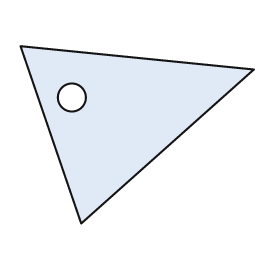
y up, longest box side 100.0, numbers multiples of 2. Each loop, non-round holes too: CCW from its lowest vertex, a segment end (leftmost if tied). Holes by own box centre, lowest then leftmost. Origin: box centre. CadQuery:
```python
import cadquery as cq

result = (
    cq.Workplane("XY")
    .moveTo(-24.0, -38.0)
    .lineTo(50.0, 28.0)
    .lineTo(-50.0, 38.0)
    .close()
    .moveTo(-28.0, 16.0)
    .circle(6.0)
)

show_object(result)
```